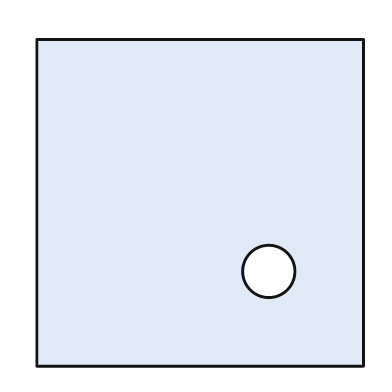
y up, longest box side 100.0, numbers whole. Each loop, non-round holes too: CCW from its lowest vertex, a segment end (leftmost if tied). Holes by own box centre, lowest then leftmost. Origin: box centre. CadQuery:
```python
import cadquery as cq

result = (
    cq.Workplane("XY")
    .moveTo(-50.0, -50.0)
    .lineTo(50.0, -50.0)
    .lineTo(50.0, 50.0)
    .lineTo(-50.0, 50.0)
    .close()
    .moveTo(21.0, -21.0)
    .circle(8.0)
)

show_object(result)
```